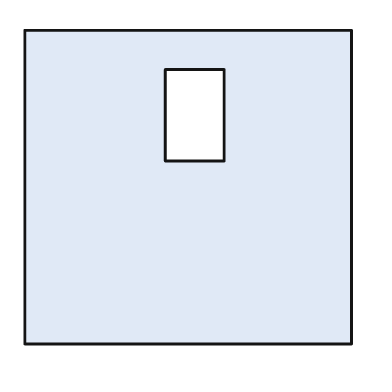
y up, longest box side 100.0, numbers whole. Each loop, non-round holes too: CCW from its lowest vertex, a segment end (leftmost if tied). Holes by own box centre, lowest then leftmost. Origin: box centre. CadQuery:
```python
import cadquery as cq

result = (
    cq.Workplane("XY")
    .moveTo(-50.0, -48.0)
    .lineTo(50.0, -48.0)
    .lineTo(50.0, 48.0)
    .lineTo(-50.0, 48.0)
    .close()
    .moveTo(-7.0, 8.0)
    .lineTo(11.0, 8.0)
    .lineTo(11.0, 36.0)
    .lineTo(-7.0, 36.0)
    .close()
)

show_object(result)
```